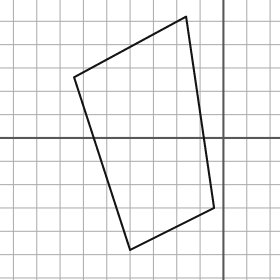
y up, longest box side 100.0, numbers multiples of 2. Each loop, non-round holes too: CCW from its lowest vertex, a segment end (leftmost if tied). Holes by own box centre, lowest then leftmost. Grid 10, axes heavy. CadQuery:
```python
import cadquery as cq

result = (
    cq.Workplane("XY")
    .moveTo(-40.0, -48.0)
    .lineTo(-4.0, -30.0)
    .lineTo(-16.0, 52.0)
    .lineTo(-64.0, 26.0)
    .close()
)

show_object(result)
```